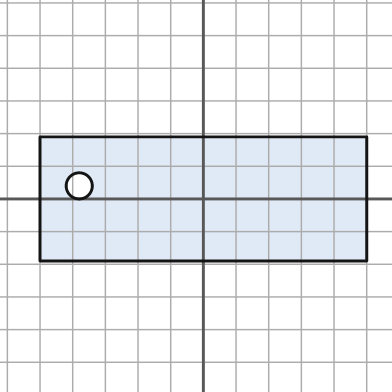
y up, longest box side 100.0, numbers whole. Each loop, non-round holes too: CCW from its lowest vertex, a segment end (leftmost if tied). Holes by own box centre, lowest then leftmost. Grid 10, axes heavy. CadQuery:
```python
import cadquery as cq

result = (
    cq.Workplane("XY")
    .moveTo(-50.0, -19.0)
    .lineTo(50.0, -19.0)
    .lineTo(50.0, 19.0)
    .lineTo(-50.0, 19.0)
    .close()
    .moveTo(-38.0, 4.0)
    .circle(4.0)
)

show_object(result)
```